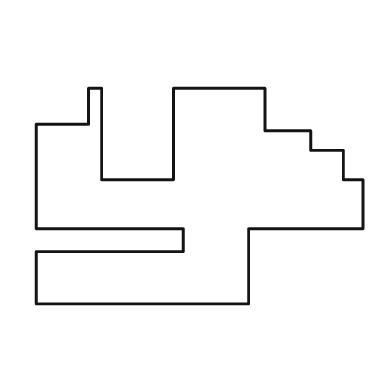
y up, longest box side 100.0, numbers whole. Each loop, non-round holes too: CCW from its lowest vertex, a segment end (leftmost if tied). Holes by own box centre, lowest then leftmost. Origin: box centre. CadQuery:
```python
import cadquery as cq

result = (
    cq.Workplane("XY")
    .moveTo(-50.0, -33.0)
    .lineTo(15.0, -33.0)
    .lineTo(15.0, -10.0)
    .lineTo(50.0, -10.0)
    .lineTo(50.0, 5.0)
    .lineTo(44.0, 5.0)
    .lineTo(44.0, 14.0)
    .lineTo(34.0, 14.0)
    .lineTo(34.0, 20.0)
    .lineTo(20.0, 20.0)
    .lineTo(20.0, 33.0)
    .lineTo(-8.0, 33.0)
    .lineTo(-8.0, 5.0)
    .lineTo(-30.0, 5.0)
    .lineTo(-30.0, 33.0)
    .lineTo(-34.0, 33.0)
    .lineTo(-34.0, 22.0)
    .lineTo(-50.0, 22.0)
    .lineTo(-50.0, -10.0)
    .lineTo(-5.0, -10.0)
    .lineTo(-5.0, -17.0)
    .lineTo(-50.0, -17.0)
    .close()
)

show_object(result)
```